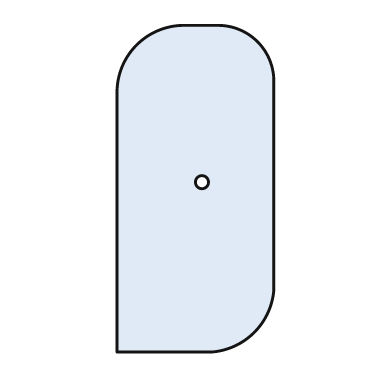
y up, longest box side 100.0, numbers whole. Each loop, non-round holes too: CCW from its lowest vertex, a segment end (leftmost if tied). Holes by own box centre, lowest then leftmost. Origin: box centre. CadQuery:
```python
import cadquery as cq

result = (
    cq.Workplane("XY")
    .moveTo(-24.0, -50.0)
    .lineTo(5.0, -50.0)
    .threePointArc((18.0, -44.0), (24.0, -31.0))
    .lineTo(24.0, 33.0)
    .threePointArc((19.0, 45.0), (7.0, 50.0))
    .lineTo(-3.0, 50.0)
    .threePointArc((-18.0, 44.0), (-24.0, 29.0))
    .close()
    .moveTo(2.0, 2.0)
    .circle(2.0)
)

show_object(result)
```